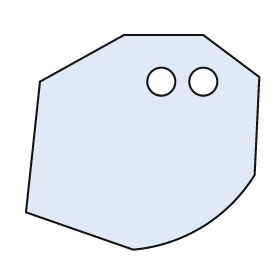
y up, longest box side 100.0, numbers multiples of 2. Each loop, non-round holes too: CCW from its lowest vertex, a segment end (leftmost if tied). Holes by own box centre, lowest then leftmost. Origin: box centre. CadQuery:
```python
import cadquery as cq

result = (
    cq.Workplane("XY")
    .moveTo(-4.0, -46.0)
    .threePointArc((26.0, -36.0), (48.0, -14.0))
    .lineTo(50.0, 28.0)
    .lineTo(26.0, 46.0)
    .lineTo(-8.0, 46.0)
    .lineTo(-44.0, 26.0)
    .lineTo(-50.0, -30.0)
    .close()
    .moveTo(8.0, 26.0)
    .circle(6.0)
    .moveTo(26.0, 26.0)
    .circle(6.0)
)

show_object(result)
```